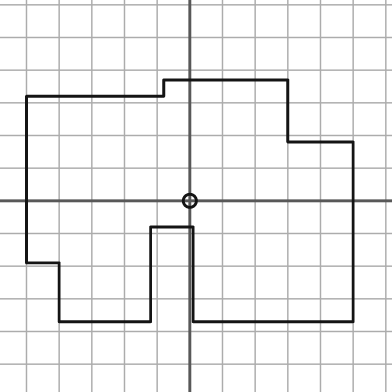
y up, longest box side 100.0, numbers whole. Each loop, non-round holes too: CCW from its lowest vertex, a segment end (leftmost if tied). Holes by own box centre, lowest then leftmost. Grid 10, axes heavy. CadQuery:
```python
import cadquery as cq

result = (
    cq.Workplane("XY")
    .moveTo(-40.0, -37.0)
    .lineTo(-12.0, -37.0)
    .lineTo(-12.0, -8.0)
    .lineTo(1.0, -8.0)
    .lineTo(1.0, -37.0)
    .lineTo(50.0, -37.0)
    .lineTo(50.0, 18.0)
    .lineTo(30.0, 18.0)
    .lineTo(30.0, 37.0)
    .lineTo(-8.0, 37.0)
    .lineTo(-8.0, 32.0)
    .lineTo(-50.0, 32.0)
    .lineTo(-50.0, -19.0)
    .lineTo(-40.0, -19.0)
    .close()
    .moveTo(0.0, 0.0)
    .circle(2.0)
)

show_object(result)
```